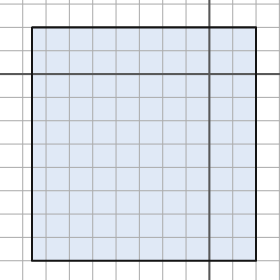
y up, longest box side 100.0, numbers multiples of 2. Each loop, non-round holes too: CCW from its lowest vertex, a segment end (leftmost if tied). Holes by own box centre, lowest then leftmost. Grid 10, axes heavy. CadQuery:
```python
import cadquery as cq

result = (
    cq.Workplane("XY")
    .moveTo(-76.0, -80.0)
    .lineTo(20.0, -80.0)
    .lineTo(20.0, 20.0)
    .lineTo(-76.0, 20.0)
    .close()
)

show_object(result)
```